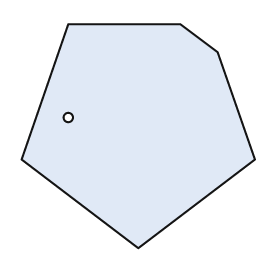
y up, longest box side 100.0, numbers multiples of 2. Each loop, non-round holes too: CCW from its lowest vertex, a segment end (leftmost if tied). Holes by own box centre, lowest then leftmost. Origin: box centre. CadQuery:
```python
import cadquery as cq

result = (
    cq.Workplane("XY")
    .moveTo(0.0, -48.0)
    .lineTo(50.0, -10.0)
    .lineTo(34.0, 36.0)
    .lineTo(18.0, 48.0)
    .lineTo(-30.0, 48.0)
    .lineTo(-50.0, -10.0)
    .close()
    .moveTo(-30.0, 8.0)
    .circle(2.0)
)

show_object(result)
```